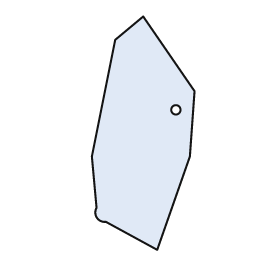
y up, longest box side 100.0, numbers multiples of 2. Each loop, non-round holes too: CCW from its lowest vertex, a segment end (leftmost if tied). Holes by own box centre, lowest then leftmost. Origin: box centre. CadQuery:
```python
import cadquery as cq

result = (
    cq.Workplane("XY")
    .moveTo(6.0, -50.0)
    .lineTo(20.0, -10.0)
    .lineTo(22.0, 18.0)
    .lineTo(0.0, 50.0)
    .lineTo(-12.0, 40.0)
    .lineTo(-22.0, -10.0)
    .lineTo(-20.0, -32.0)
    .threePointArc((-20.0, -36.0), (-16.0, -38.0))
    .close()
    .moveTo(14.0, 10.0)
    .circle(2.0)
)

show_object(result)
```